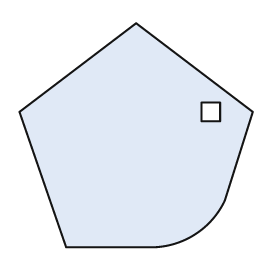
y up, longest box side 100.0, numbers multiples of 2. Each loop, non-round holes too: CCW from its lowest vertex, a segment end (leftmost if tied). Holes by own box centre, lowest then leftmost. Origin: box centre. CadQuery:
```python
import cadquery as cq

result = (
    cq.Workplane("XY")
    .moveTo(-30.0, -48.0)
    .lineTo(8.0, -48.0)
    .threePointArc((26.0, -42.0), (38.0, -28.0))
    .lineTo(50.0, 10.0)
    .lineTo(0.0, 48.0)
    .lineTo(-50.0, 10.0)
    .close()
    .moveTo(28.0, 6.0)
    .lineTo(36.0, 6.0)
    .lineTo(36.0, 14.0)
    .lineTo(28.0, 14.0)
    .close()
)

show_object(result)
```